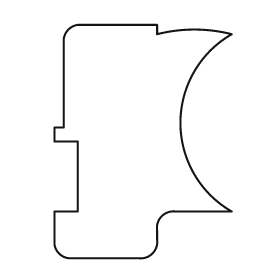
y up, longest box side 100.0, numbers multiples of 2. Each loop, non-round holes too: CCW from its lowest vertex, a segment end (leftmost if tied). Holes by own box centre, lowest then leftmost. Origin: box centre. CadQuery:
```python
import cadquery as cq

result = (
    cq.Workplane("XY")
    .moveTo(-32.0, -50.0)
    .lineTo(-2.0, -50.0)
    .threePointArc((4.0, -48.0), (6.0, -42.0))
    .lineTo(6.0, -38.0)
    .threePointArc((8.0, -32.0), (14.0, -30.0))
    .lineTo(38.0, -30.0)
    .threePointArc((16.0, 8.0), (38.0, 46.0))
    .threePointArc((22.0, 48.0), (6.0, 46.0))
    .lineTo(6.0, 50.0)
    .lineTo(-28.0, 50.0)
    .threePointArc((-32.0, 48.0), (-34.0, 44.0))
    .lineTo(-34.0, 6.0)
    .lineTo(-38.0, 6.0)
    .lineTo(-38.0, 0.0)
    .lineTo(-28.0, 0.0)
    .lineTo(-28.0, -30.0)
    .lineTo(-38.0, -30.0)
    .lineTo(-38.0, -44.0)
    .threePointArc((-36.0, -48.0), (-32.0, -50.0))
    .close()
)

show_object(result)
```